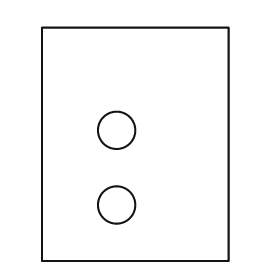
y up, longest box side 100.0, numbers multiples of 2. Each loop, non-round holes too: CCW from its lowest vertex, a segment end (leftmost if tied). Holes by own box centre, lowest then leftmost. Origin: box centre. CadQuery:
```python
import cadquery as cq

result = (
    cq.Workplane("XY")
    .moveTo(-40.0, -50.0)
    .lineTo(40.0, -50.0)
    .lineTo(40.0, 50.0)
    .lineTo(-40.0, 50.0)
    .close()
    .moveTo(-8.0, -26.0)
    .circle(8.0)
    .moveTo(-8.0, 6.0)
    .circle(8.0)
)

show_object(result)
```